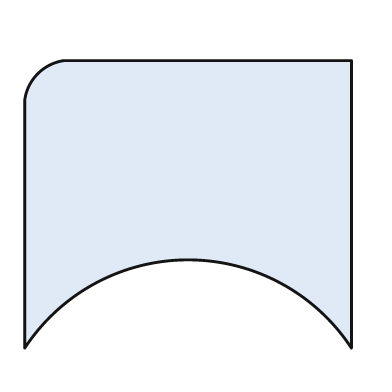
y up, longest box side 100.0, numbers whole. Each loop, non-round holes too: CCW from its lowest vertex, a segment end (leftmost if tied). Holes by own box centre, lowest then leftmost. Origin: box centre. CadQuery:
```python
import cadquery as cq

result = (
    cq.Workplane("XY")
    .moveTo(-50.0, -44.0)
    .threePointArc((0.0, -17.0), (50.0, -44.0))
    .lineTo(50.0, 44.0)
    .lineTo(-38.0, 44.0)
    .threePointArc((-46.0, 40.0), (-50.0, 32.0))
    .close()
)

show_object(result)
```